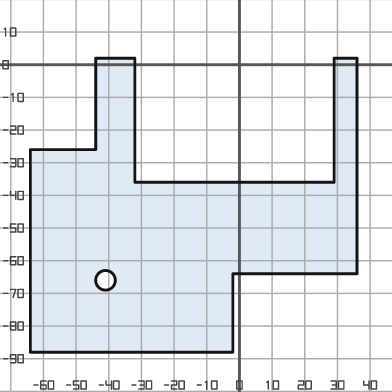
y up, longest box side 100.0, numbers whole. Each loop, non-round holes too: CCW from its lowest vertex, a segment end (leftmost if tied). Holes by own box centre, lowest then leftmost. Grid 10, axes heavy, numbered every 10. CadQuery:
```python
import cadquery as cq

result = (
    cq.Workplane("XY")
    .moveTo(-64.0, -88.0)
    .lineTo(-2.0, -88.0)
    .lineTo(-2.0, -64.0)
    .lineTo(36.0, -64.0)
    .lineTo(36.0, 2.0)
    .lineTo(29.0, 2.0)
    .lineTo(29.0, -36.0)
    .lineTo(-32.0, -36.0)
    .lineTo(-32.0, 2.0)
    .lineTo(-44.0, 2.0)
    .lineTo(-44.0, -26.0)
    .lineTo(-64.0, -26.0)
    .close()
    .moveTo(-41.0, -66.0)
    .circle(3.0)
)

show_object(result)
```